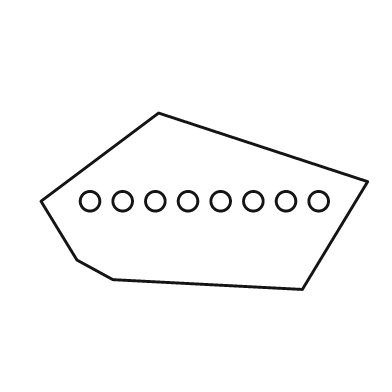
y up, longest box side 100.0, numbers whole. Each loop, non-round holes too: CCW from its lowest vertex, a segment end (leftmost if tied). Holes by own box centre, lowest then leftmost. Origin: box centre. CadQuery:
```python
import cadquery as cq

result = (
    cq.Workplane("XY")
    .moveTo(30.0, -27.0)
    .lineTo(50.0, 6.0)
    .lineTo(-14.0, 27.0)
    .lineTo(-50.0, 0.0)
    .lineTo(-39.0, -18.0)
    .lineTo(-28.0, -24.0)
    .close()
    .moveTo(-35.0, 0.0)
    .circle(3.0)
    .moveTo(-25.0, 0.0)
    .circle(3.0)
    .moveTo(-15.0, 0.0)
    .circle(3.0)
    .moveTo(-5.0, 0.0)
    .circle(3.0)
    .moveTo(5.0, 0.0)
    .circle(3.0)
    .moveTo(15.0, 0.0)
    .circle(3.0)
    .moveTo(25.0, 0.0)
    .circle(3.0)
    .moveTo(35.0, 0.0)
    .circle(3.0)
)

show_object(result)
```